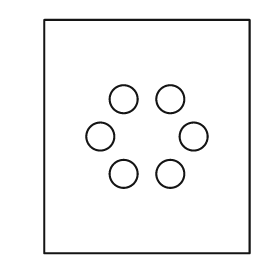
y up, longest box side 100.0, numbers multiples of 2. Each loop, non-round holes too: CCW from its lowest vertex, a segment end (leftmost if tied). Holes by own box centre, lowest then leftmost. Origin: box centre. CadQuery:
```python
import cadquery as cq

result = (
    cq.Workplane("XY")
    .moveTo(-44.0, -50.0)
    .lineTo(44.0, -50.0)
    .lineTo(44.0, 50.0)
    .lineTo(-44.0, 50.0)
    .close()
    .moveTo(-10.0, -16.0)
    .circle(6.0)
    .moveTo(10.0, -16.0)
    .circle(6.0)
    .moveTo(-20.0, 0.0)
    .circle(6.0)
    .moveTo(20.0, 0.0)
    .circle(6.0)
    .moveTo(-10.0, 16.0)
    .circle(6.0)
    .moveTo(10.0, 16.0)
    .circle(6.0)
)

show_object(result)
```